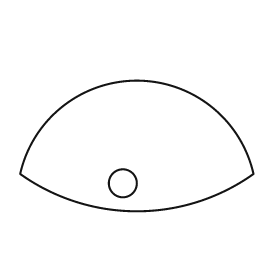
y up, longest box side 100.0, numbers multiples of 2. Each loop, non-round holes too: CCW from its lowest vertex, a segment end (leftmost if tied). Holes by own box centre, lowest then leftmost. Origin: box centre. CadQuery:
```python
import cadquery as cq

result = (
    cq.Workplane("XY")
    .moveTo(-50.0, -12.0)
    .threePointArc((0.0, -28.0), (50.0, -12.0))
    .threePointArc((0.0, 28.0), (-50.0, -12.0))
    .close()
    .moveTo(-6.0, -16.0)
    .circle(6.0)
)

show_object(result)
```